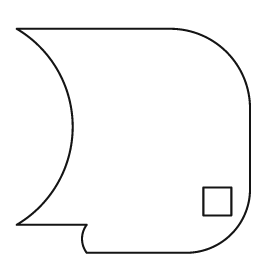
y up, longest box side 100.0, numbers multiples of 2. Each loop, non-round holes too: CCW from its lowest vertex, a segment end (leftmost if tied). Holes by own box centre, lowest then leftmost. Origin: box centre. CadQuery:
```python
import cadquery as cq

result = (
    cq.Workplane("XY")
    .moveTo(-20.0, -48.0)
    .lineTo(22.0, -48.0)
    .threePointArc((42.0, -40.0), (50.0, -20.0))
    .lineTo(50.0, 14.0)
    .threePointArc((40.0, 38.0), (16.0, 48.0))
    .lineTo(-50.0, 48.0)
    .threePointArc((-26.0, 6.0), (-50.0, -36.0))
    .lineTo(-20.0, -36.0)
    .threePointArc((-22.0, -42.0), (-20.0, -48.0))
    .close()
    .moveTo(30.0, -32.0)
    .lineTo(42.0, -32.0)
    .lineTo(42.0, -20.0)
    .lineTo(30.0, -20.0)
    .close()
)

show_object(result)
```